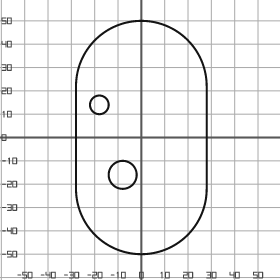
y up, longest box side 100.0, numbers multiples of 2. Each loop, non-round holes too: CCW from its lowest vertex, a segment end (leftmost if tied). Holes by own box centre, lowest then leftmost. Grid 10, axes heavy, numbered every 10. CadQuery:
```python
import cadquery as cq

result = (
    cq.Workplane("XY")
    .moveTo(-28.0, -22.0)
    .threePointArc((0.0, -50.0), (28.0, -22.0))
    .lineTo(28.0, 22.0)
    .threePointArc((0.0, 50.0), (-28.0, 22.0))
    .close()
    .moveTo(-8.0, -16.0)
    .circle(6.0)
    .moveTo(-18.0, 14.0)
    .circle(4.0)
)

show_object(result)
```